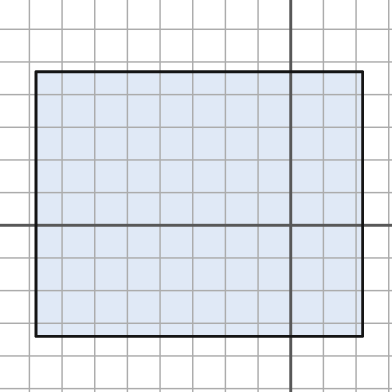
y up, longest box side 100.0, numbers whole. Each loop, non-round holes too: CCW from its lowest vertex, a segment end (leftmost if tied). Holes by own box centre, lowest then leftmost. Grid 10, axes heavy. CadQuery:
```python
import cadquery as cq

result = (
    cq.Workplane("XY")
    .moveTo(-78.0, -34.0)
    .lineTo(22.0, -34.0)
    .lineTo(22.0, 47.0)
    .lineTo(-78.0, 47.0)
    .close()
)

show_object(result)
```